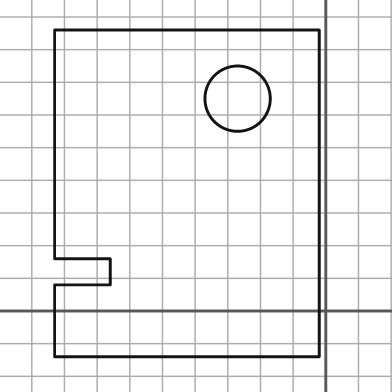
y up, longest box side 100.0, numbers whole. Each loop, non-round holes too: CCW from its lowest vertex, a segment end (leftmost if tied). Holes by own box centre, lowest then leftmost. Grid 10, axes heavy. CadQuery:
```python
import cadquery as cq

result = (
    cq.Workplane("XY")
    .moveTo(-83.0, -14.0)
    .lineTo(-2.0, -14.0)
    .lineTo(-2.0, 86.0)
    .lineTo(-83.0, 86.0)
    .lineTo(-83.0, 16.0)
    .lineTo(-66.0, 16.0)
    .lineTo(-66.0, 8.0)
    .lineTo(-83.0, 8.0)
    .close()
    .moveTo(-27.0, 65.0)
    .circle(10.0)
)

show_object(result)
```